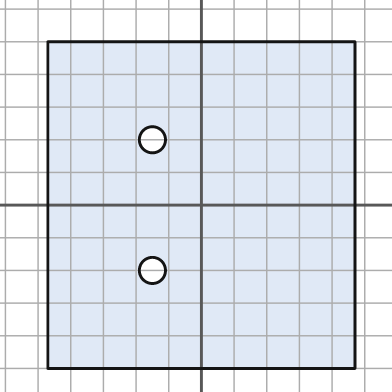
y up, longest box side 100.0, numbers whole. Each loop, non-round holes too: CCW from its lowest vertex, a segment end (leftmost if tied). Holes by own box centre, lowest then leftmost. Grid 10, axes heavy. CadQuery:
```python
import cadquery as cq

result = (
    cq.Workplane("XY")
    .moveTo(-47.0, -50.0)
    .lineTo(47.0, -50.0)
    .lineTo(47.0, 50.0)
    .lineTo(-47.0, 50.0)
    .close()
    .moveTo(-15.0, -20.0)
    .circle(4.0)
    .moveTo(-15.0, 20.0)
    .circle(4.0)
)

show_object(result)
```